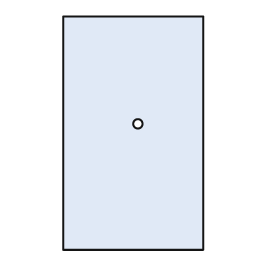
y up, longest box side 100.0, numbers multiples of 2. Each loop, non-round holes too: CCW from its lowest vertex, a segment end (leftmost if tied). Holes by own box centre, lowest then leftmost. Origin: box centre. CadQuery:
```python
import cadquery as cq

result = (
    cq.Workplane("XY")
    .moveTo(-30.0, -50.0)
    .lineTo(30.0, -50.0)
    .lineTo(30.0, 50.0)
    .lineTo(-30.0, 50.0)
    .close()
    .moveTo(2.0, 4.0)
    .circle(2.0)
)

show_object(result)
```